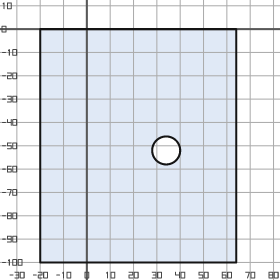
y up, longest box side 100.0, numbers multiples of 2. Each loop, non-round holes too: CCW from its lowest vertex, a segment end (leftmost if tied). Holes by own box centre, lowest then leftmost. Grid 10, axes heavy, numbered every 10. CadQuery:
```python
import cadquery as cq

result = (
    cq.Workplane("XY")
    .moveTo(-20.0, -100.0)
    .lineTo(64.0, -100.0)
    .lineTo(64.0, 0.0)
    .lineTo(-20.0, 0.0)
    .close()
    .moveTo(34.0, -52.0)
    .circle(6.0)
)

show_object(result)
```